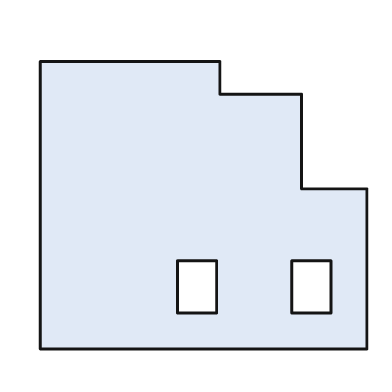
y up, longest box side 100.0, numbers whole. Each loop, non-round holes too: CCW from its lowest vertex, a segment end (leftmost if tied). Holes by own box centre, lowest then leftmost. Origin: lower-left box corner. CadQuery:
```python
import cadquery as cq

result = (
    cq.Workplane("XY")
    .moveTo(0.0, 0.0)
    .lineTo(100.0, 0.0)
    .lineTo(100.0, 49.0)
    .lineTo(80.0, 49.0)
    .lineTo(80.0, 78.0)
    .lineTo(55.0, 78.0)
    .lineTo(55.0, 88.0)
    .lineTo(0.0, 88.0)
    .close()
    .moveTo(42.0, 11.0)
    .lineTo(54.0, 11.0)
    .lineTo(54.0, 27.0)
    .lineTo(42.0, 27.0)
    .close()
    .moveTo(77.0, 11.0)
    .lineTo(89.0, 11.0)
    .lineTo(89.0, 27.0)
    .lineTo(77.0, 27.0)
    .close()
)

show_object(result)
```